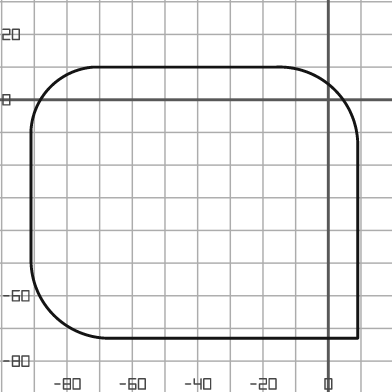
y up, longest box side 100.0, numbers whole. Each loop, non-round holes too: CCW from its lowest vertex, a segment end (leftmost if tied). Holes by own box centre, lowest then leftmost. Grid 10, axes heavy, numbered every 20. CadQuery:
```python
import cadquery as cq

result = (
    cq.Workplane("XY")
    .moveTo(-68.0, -73.0)
    .lineTo(9.0, -73.0)
    .lineTo(9.0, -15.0)
    .threePointArc((2.0, 3.0), (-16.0, 10.0))
    .lineTo(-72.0, 10.0)
    .threePointArc((-85.0, 4.0), (-91.0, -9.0))
    .lineTo(-91.0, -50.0)
    .threePointArc((-84.0, -66.0), (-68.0, -73.0))
    .close()
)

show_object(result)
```